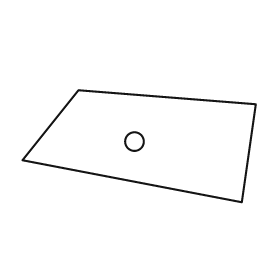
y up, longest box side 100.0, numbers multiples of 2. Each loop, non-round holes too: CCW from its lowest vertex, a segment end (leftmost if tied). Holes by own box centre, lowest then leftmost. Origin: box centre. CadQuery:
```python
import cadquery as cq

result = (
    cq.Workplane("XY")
    .moveTo(44.0, -24.0)
    .lineTo(50.0, 18.0)
    .lineTo(-26.0, 24.0)
    .lineTo(-50.0, -6.0)
    .close()
    .moveTo(-2.0, 2.0)
    .circle(4.0)
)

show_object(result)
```